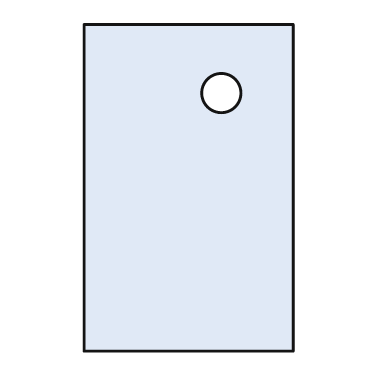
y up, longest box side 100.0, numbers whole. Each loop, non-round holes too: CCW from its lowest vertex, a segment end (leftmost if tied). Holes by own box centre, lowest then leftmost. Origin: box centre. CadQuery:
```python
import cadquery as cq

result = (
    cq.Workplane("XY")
    .moveTo(-32.0, -50.0)
    .lineTo(32.0, -50.0)
    .lineTo(32.0, 50.0)
    .lineTo(-32.0, 50.0)
    .close()
    .moveTo(10.0, 29.0)
    .circle(6.0)
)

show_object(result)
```